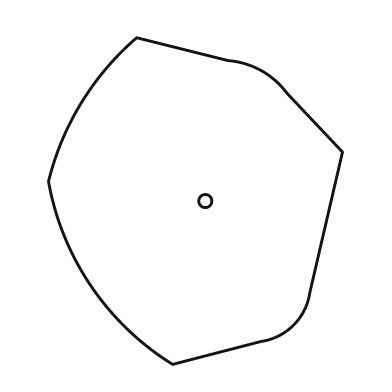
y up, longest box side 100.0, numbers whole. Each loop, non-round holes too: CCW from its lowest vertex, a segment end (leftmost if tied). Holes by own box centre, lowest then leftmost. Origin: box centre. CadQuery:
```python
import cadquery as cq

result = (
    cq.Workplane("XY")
    .moveTo(-7.0, -50.0)
    .lineTo(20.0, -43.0)
    .threePointArc((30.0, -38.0), (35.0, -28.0))
    .lineTo(45.0, 15.0)
    .lineTo(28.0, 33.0)
    .threePointArc((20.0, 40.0), (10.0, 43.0))
    .lineTo(-18.0, 50.0)
    .threePointArc((-35.0, 30.0), (-45.0, 6.0))
    .threePointArc((-32.0, -26.0), (-7.0, -50.0))
    .close()
    .moveTo(3.0, 0.0)
    .circle(2.0)
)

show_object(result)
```